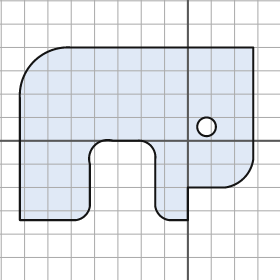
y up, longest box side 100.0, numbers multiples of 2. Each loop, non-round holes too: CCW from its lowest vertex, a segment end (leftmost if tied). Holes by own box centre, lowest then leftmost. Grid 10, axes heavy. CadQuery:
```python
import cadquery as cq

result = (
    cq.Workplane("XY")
    .moveTo(-72.0, -34.0)
    .lineTo(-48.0, -34.0)
    .threePointArc((-44.0, -32.0), (-42.0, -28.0))
    .lineTo(-42.0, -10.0)
    .threePointArc((-40.0, -2.0), (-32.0, 0.0))
    .lineTo(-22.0, 0.0)
    .threePointArc((-16.0, -2.0), (-14.0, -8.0))
    .lineTo(-14.0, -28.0)
    .threePointArc((-12.0, -32.0), (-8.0, -34.0))
    .lineTo(0.0, -34.0)
    .lineTo(0.0, -20.0)
    .lineTo(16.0, -20.0)
    .threePointArc((24.0, -16.0), (28.0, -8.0))
    .lineTo(28.0, 40.0)
    .lineTo(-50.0, 40.0)
    .threePointArc((-66.0, 34.0), (-72.0, 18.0))
    .close()
    .moveTo(8.0, 6.0)
    .circle(4.0)
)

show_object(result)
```